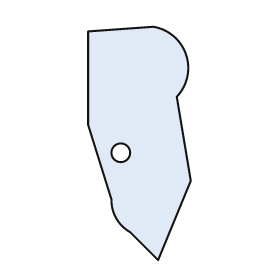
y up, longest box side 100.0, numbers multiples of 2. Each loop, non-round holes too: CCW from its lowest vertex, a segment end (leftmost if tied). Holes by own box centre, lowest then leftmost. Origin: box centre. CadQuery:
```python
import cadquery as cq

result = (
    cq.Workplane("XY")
    .moveTo(8.0, -50.0)
    .lineTo(22.0, -16.0)
    .lineTo(16.0, 20.0)
    .threePointArc((20.0, 38.0), (6.0, 50.0))
    .lineTo(-22.0, 48.0)
    .lineTo(-22.0, 8.0)
    .lineTo(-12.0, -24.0)
    .threePointArc((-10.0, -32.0), (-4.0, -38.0))
    .close()
    .moveTo(-8.0, -4.0)
    .circle(4.0)
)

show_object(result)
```